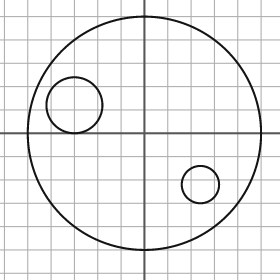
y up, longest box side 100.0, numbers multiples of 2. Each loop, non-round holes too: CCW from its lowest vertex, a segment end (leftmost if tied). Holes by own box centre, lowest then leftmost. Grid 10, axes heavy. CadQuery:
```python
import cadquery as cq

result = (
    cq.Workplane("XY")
    .moveTo(0.0, 0.0)
    .circle(50.0)
    .moveTo(24.0, -22.0)
    .circle(8.0)
    .moveTo(-30.0, 12.0)
    .circle(12.0)
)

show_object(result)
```